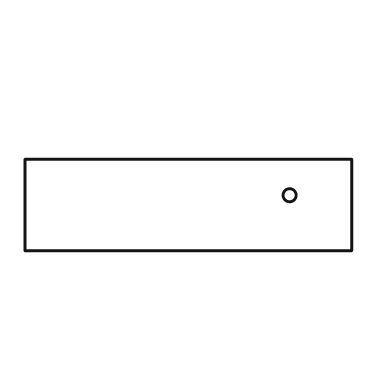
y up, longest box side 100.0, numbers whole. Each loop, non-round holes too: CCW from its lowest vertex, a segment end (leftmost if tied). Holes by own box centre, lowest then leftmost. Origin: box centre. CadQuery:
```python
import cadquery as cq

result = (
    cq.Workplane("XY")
    .moveTo(-50.0, -14.0)
    .lineTo(50.0, -14.0)
    .lineTo(50.0, 14.0)
    .lineTo(-50.0, 14.0)
    .close()
    .moveTo(31.0, 3.0)
    .circle(2.0)
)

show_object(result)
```